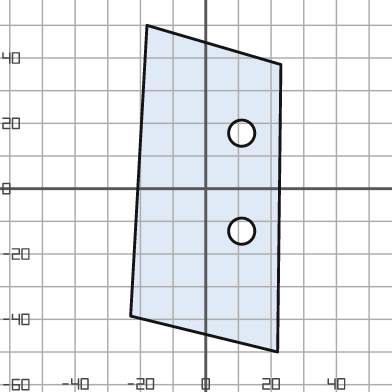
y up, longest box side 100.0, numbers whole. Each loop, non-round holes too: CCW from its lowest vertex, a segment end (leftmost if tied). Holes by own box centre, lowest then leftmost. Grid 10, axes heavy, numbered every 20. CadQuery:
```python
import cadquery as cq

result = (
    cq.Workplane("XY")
    .moveTo(22.0, -50.0)
    .lineTo(23.0, 38.0)
    .lineTo(-18.0, 50.0)
    .lineTo(-23.0, -39.0)
    .close()
    .moveTo(11.0, -13.0)
    .circle(4.0)
    .moveTo(11.0, 17.0)
    .circle(4.0)
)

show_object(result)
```